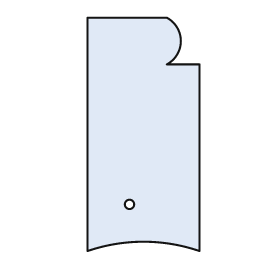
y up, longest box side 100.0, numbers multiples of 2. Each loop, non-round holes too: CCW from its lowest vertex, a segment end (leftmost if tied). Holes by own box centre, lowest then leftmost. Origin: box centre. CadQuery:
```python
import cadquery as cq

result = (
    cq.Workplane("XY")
    .moveTo(-24.0, -50.0)
    .threePointArc((0.0, -46.0), (24.0, -50.0))
    .lineTo(24.0, 30.0)
    .lineTo(10.0, 30.0)
    .threePointArc((16.0, 40.0), (10.0, 50.0))
    .lineTo(-24.0, 50.0)
    .close()
    .moveTo(-6.0, -30.0)
    .circle(2.0)
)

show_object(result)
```